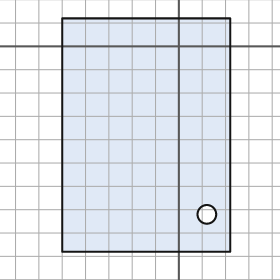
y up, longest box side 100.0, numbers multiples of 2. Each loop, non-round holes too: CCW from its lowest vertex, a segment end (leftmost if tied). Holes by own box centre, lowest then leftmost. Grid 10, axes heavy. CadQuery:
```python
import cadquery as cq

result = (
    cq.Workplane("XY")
    .moveTo(-50.0, -88.0)
    .lineTo(22.0, -88.0)
    .lineTo(22.0, 12.0)
    .lineTo(-50.0, 12.0)
    .close()
    .moveTo(12.0, -72.0)
    .circle(4.0)
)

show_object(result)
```